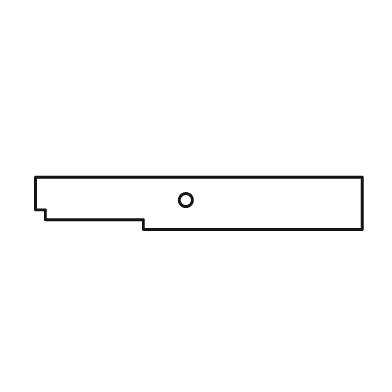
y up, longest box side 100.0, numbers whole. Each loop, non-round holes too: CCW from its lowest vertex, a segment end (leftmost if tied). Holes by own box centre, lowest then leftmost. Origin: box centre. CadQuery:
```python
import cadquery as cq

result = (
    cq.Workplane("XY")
    .moveTo(-17.0, -8.0)
    .lineTo(50.0, -8.0)
    .lineTo(50.0, 8.0)
    .lineTo(-50.0, 8.0)
    .lineTo(-50.0, -2.0)
    .lineTo(-47.0, -2.0)
    .lineTo(-47.0, -5.0)
    .lineTo(-17.0, -5.0)
    .close()
    .moveTo(-4.0, 1.0)
    .circle(2.0)
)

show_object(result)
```